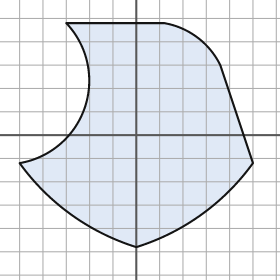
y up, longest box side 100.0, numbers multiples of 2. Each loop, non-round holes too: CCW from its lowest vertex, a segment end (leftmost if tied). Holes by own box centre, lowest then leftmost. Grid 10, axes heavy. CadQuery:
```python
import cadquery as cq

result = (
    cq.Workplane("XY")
    .moveTo(0.0, -48.0)
    .threePointArc((28.0, -34.0), (50.0, -12.0))
    .lineTo(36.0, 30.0)
    .threePointArc((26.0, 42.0), (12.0, 48.0))
    .lineTo(-30.0, 48.0)
    .threePointArc((-22.0, 12.0), (-50.0, -12.0))
    .threePointArc((-28.0, -34.0), (0.0, -48.0))
    .close()
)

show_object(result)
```